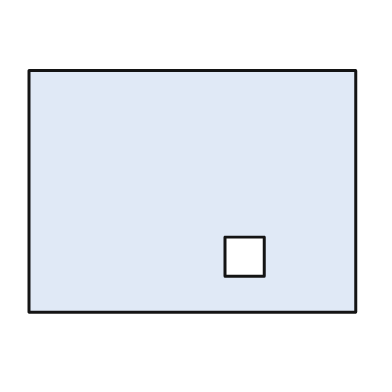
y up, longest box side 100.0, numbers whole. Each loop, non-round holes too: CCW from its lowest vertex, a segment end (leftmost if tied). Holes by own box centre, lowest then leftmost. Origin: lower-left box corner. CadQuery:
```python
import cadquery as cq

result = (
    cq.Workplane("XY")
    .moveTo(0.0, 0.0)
    .lineTo(100.0, 0.0)
    .lineTo(100.0, 74.0)
    .lineTo(0.0, 74.0)
    .close()
    .moveTo(60.0, 11.0)
    .lineTo(72.0, 11.0)
    .lineTo(72.0, 23.0)
    .lineTo(60.0, 23.0)
    .close()
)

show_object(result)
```